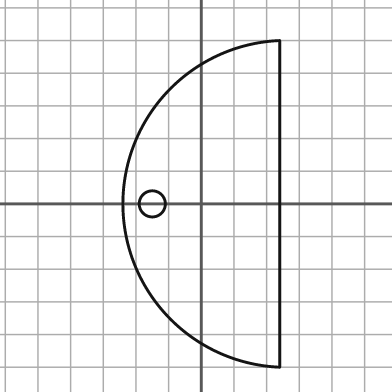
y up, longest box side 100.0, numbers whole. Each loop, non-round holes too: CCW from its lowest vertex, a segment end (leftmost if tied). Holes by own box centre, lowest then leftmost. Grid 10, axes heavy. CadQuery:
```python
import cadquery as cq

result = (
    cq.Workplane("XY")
    .moveTo(24.0, -50.0)
    .lineTo(24.0, 50.0)
    .threePointArc((-24.0, 0.0), (24.0, -50.0))
    .close()
    .moveTo(-15.0, 0.0)
    .circle(4.0)
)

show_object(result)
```